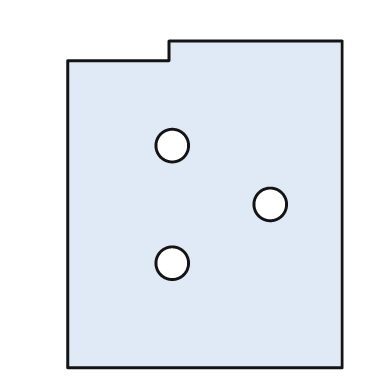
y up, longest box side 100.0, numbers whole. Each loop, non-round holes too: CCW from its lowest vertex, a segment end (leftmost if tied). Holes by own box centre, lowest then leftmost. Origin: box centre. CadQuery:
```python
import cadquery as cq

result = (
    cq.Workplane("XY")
    .moveTo(-42.0, -50.0)
    .lineTo(42.0, -50.0)
    .lineTo(42.0, 50.0)
    .lineTo(-11.0, 50.0)
    .lineTo(-11.0, 44.0)
    .lineTo(-42.0, 44.0)
    .close()
    .moveTo(-10.0, -18.0)
    .circle(5.0)
    .moveTo(20.0, 0.0)
    .circle(5.0)
    .moveTo(-10.0, 18.0)
    .circle(5.0)
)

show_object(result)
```